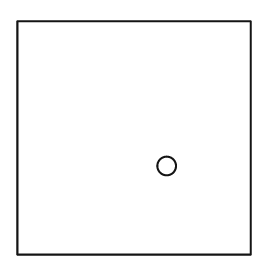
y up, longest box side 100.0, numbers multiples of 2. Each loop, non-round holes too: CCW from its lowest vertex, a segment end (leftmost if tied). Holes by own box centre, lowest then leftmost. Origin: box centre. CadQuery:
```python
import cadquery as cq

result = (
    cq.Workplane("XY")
    .moveTo(-50.0, -50.0)
    .lineTo(50.0, -50.0)
    .lineTo(50.0, 50.0)
    .lineTo(-50.0, 50.0)
    .close()
    .moveTo(14.0, -12.0)
    .circle(4.0)
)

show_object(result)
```